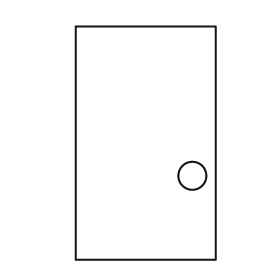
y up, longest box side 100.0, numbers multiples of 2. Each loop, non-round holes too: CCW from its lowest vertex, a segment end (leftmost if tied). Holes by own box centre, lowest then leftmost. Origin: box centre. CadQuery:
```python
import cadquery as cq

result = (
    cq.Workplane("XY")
    .moveTo(-30.0, -50.0)
    .lineTo(30.0, -50.0)
    .lineTo(30.0, 50.0)
    .lineTo(-30.0, 50.0)
    .close()
    .moveTo(20.0, -14.0)
    .circle(6.0)
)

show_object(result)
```